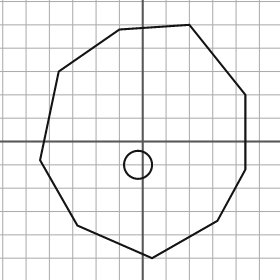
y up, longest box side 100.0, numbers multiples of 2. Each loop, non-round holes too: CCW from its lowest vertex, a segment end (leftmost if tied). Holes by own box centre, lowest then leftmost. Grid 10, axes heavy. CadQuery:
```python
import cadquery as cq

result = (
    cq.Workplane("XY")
    .moveTo(4.0, -50.0)
    .lineTo(32.0, -34.0)
    .lineTo(44.0, -12.0)
    .lineTo(44.0, 20.0)
    .lineTo(20.0, 50.0)
    .lineTo(-10.0, 48.0)
    .lineTo(-36.0, 30.0)
    .lineTo(-44.0, -8.0)
    .lineTo(-28.0, -36.0)
    .close()
    .moveTo(-2.0, -10.0)
    .circle(6.0)
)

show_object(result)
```